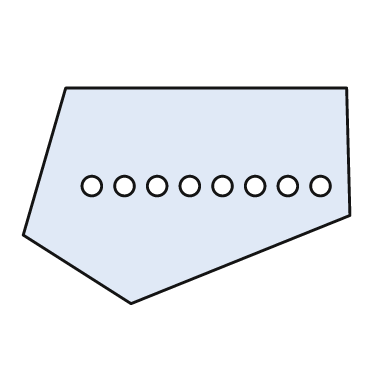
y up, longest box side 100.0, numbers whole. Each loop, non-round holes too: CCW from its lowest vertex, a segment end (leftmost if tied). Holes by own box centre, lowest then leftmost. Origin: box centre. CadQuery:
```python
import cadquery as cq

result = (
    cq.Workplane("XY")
    .moveTo(-17.0, -33.0)
    .lineTo(50.0, -6.0)
    .lineTo(49.0, 33.0)
    .lineTo(-37.0, 33.0)
    .lineTo(-50.0, -12.0)
    .close()
    .moveTo(-29.0, 3.0)
    .circle(3.0)
    .moveTo(-19.0, 3.0)
    .circle(3.0)
    .moveTo(-9.0, 3.0)
    .circle(3.0)
    .moveTo(1.0, 3.0)
    .circle(3.0)
    .moveTo(11.0, 3.0)
    .circle(3.0)
    .moveTo(21.0, 3.0)
    .circle(3.0)
    .moveTo(31.0, 3.0)
    .circle(3.0)
    .moveTo(41.0, 3.0)
    .circle(3.0)
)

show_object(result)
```